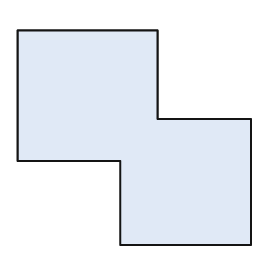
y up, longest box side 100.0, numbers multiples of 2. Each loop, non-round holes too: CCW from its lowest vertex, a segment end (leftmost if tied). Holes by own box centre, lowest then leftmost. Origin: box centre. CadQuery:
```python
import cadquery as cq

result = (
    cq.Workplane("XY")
    .moveTo(-6.0, -46.0)
    .lineTo(50.0, -46.0)
    .lineTo(50.0, 8.0)
    .lineTo(10.0, 8.0)
    .lineTo(10.0, 46.0)
    .lineTo(-50.0, 46.0)
    .lineTo(-50.0, -10.0)
    .lineTo(-6.0, -10.0)
    .close()
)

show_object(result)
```